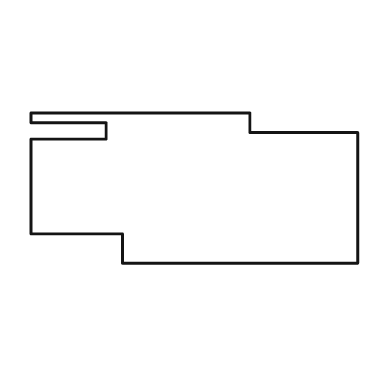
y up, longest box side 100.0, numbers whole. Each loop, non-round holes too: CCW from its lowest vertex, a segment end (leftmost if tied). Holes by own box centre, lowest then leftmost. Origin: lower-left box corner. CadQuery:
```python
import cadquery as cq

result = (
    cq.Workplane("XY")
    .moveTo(28.0, 0.0)
    .lineTo(100.0, 0.0)
    .lineTo(100.0, 40.0)
    .lineTo(67.0, 40.0)
    .lineTo(67.0, 46.0)
    .lineTo(0.0, 46.0)
    .lineTo(0.0, 43.0)
    .lineTo(23.0, 43.0)
    .lineTo(23.0, 38.0)
    .lineTo(0.0, 38.0)
    .lineTo(0.0, 9.0)
    .lineTo(28.0, 9.0)
    .close()
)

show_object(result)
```